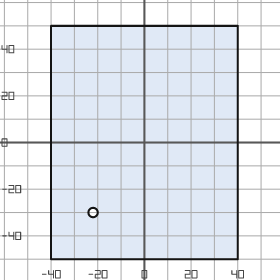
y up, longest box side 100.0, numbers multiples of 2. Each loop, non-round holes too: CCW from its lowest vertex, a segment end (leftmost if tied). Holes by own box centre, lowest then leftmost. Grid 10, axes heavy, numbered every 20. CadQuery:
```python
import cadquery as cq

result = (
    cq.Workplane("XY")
    .moveTo(-40.0, -50.0)
    .lineTo(40.0, -50.0)
    .lineTo(40.0, 50.0)
    .lineTo(-40.0, 50.0)
    .close()
    .moveTo(-22.0, -30.0)
    .circle(2.0)
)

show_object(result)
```